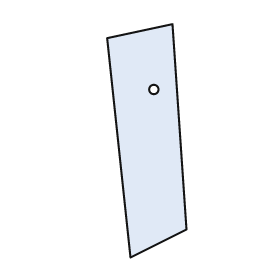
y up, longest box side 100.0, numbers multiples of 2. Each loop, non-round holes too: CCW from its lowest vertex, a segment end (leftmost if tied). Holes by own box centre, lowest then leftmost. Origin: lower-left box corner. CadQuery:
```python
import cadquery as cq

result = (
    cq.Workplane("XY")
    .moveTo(10.0, 0.0)
    .lineTo(34.0, 12.0)
    .lineTo(28.0, 100.0)
    .lineTo(0.0, 94.0)
    .close()
    .moveTo(20.0, 72.0)
    .circle(2.0)
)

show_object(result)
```